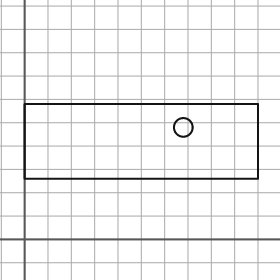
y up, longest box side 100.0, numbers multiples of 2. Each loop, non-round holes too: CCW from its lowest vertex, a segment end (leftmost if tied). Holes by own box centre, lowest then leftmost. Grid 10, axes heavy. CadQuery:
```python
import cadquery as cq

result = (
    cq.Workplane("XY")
    .moveTo(0.0, 26.0)
    .lineTo(100.0, 26.0)
    .lineTo(100.0, 58.0)
    .lineTo(0.0, 58.0)
    .close()
    .moveTo(68.0, 48.0)
    .circle(4.0)
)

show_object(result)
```